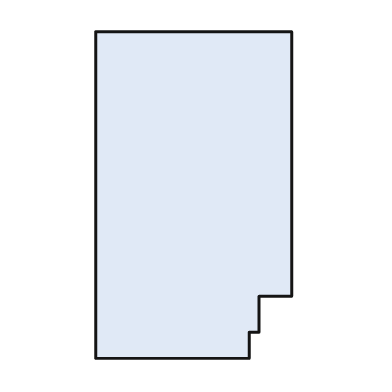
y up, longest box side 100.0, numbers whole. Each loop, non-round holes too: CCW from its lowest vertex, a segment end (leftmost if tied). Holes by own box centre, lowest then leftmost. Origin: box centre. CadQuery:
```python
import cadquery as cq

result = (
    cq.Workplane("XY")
    .moveTo(-30.0, -50.0)
    .lineTo(17.0, -50.0)
    .lineTo(17.0, -42.0)
    .lineTo(20.0, -42.0)
    .lineTo(20.0, -31.0)
    .lineTo(30.0, -31.0)
    .lineTo(30.0, 50.0)
    .lineTo(-30.0, 50.0)
    .close()
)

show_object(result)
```